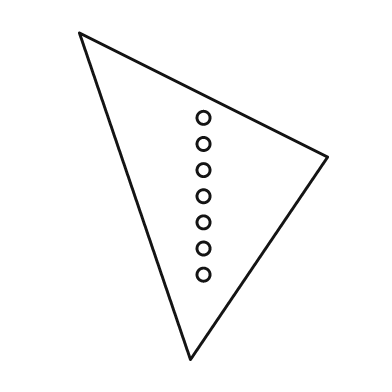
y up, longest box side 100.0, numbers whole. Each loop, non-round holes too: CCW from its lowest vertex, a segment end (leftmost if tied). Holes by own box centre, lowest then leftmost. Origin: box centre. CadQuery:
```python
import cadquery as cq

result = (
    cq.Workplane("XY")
    .moveTo(-4.0, -50.0)
    .lineTo(38.0, 12.0)
    .lineTo(-38.0, 50.0)
    .close()
    .moveTo(0.0, -24.0)
    .circle(2.0)
    .moveTo(0.0, -16.0)
    .circle(2.0)
    .moveTo(0.0, -8.0)
    .circle(2.0)
    .moveTo(0.0, 0.0)
    .circle(2.0)
    .moveTo(0.0, 8.0)
    .circle(2.0)
    .moveTo(0.0, 16.0)
    .circle(2.0)
    .moveTo(0.0, 24.0)
    .circle(2.0)
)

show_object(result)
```